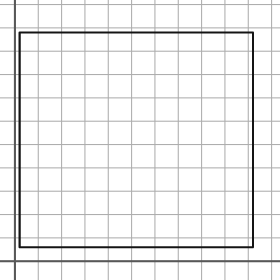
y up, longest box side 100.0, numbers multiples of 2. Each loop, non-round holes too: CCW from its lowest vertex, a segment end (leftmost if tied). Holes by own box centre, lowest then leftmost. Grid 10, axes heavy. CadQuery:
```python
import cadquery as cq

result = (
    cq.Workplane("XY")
    .moveTo(2.0, 6.0)
    .lineTo(102.0, 6.0)
    .lineTo(102.0, 98.0)
    .lineTo(2.0, 98.0)
    .close()
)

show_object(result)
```